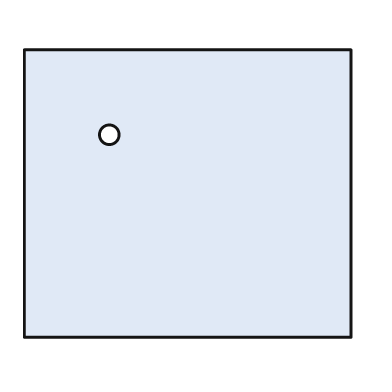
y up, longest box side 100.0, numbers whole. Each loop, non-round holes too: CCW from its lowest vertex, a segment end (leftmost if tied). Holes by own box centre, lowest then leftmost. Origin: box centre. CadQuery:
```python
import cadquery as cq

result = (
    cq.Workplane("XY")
    .moveTo(-50.0, -44.0)
    .lineTo(50.0, -44.0)
    .lineTo(50.0, 44.0)
    .lineTo(-50.0, 44.0)
    .close()
    .moveTo(-24.0, 18.0)
    .circle(3.0)
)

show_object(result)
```